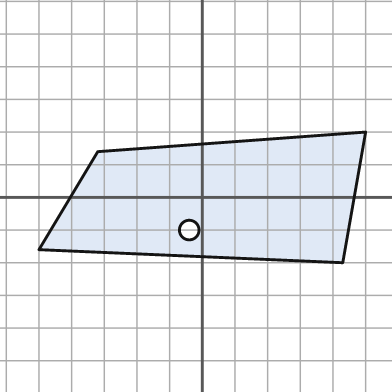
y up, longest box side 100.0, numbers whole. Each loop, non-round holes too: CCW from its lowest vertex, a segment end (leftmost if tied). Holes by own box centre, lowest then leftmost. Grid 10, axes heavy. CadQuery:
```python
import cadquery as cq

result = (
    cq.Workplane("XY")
    .moveTo(43.0, -20.0)
    .lineTo(50.0, 20.0)
    .lineTo(-32.0, 14.0)
    .lineTo(-50.0, -16.0)
    .close()
    .moveTo(-4.0, -10.0)
    .circle(3.0)
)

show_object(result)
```